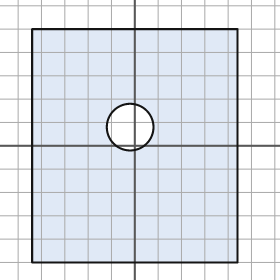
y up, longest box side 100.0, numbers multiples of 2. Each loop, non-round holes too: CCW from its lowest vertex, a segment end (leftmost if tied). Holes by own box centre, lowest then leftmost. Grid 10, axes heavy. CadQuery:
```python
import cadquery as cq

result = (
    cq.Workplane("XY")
    .moveTo(-44.0, -50.0)
    .lineTo(44.0, -50.0)
    .lineTo(44.0, 50.0)
    .lineTo(-44.0, 50.0)
    .close()
    .moveTo(-2.0, 8.0)
    .circle(10.0)
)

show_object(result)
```